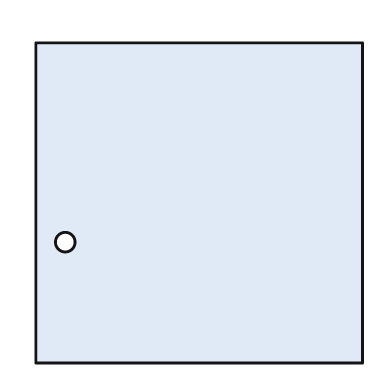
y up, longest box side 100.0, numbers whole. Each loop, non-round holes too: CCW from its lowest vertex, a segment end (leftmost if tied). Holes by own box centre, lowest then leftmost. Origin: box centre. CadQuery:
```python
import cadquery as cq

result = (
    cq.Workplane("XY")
    .moveTo(-50.0, -49.0)
    .lineTo(50.0, -49.0)
    .lineTo(50.0, 49.0)
    .lineTo(-50.0, 49.0)
    .close()
    .moveTo(-41.0, -12.0)
    .circle(3.0)
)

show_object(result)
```